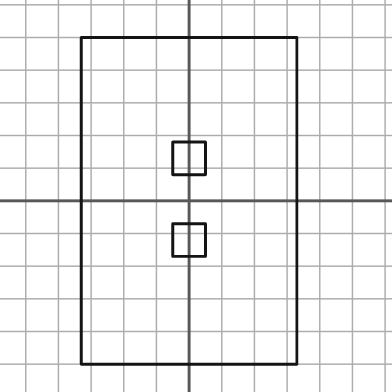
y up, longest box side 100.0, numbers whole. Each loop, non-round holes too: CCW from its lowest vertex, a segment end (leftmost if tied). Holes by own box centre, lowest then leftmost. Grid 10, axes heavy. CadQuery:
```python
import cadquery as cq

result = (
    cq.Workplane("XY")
    .moveTo(-33.0, -50.0)
    .lineTo(33.0, -50.0)
    .lineTo(33.0, 50.0)
    .lineTo(-33.0, 50.0)
    .close()
    .moveTo(-5.0, -17.0)
    .lineTo(5.0, -17.0)
    .lineTo(5.0, -7.0)
    .lineTo(-5.0, -7.0)
    .close()
    .moveTo(-5.0, 8.0)
    .lineTo(5.0, 8.0)
    .lineTo(5.0, 18.0)
    .lineTo(-5.0, 18.0)
    .close()
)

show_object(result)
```